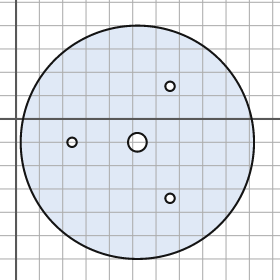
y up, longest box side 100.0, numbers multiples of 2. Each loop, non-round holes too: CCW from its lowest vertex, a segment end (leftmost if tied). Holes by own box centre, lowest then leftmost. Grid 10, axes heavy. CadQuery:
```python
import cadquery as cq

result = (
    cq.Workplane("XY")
    .moveTo(52.0, -10.0)
    .circle(50.0)
    .moveTo(66.0, -34.0)
    .circle(2.0)
    .moveTo(24.0, -10.0)
    .circle(2.0)
    .moveTo(52.0, -10.0)
    .circle(4.0)
    .moveTo(66.0, 14.0)
    .circle(2.0)
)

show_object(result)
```